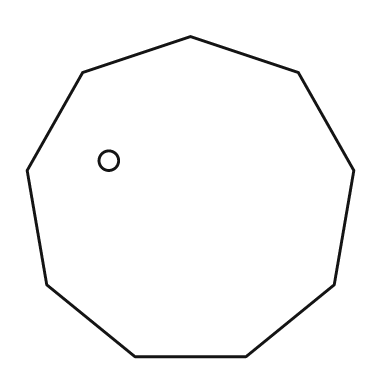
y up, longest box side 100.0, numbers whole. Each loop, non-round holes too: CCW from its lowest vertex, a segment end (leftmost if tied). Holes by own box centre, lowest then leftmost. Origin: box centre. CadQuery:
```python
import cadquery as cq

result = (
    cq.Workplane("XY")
    .moveTo(-17.0, -49.0)
    .lineTo(17.0, -49.0)
    .lineTo(44.0, -27.0)
    .lineTo(50.0, 8.0)
    .lineTo(33.0, 38.0)
    .lineTo(0.0, 49.0)
    .lineTo(-33.0, 38.0)
    .lineTo(-50.0, 8.0)
    .lineTo(-44.0, -27.0)
    .close()
    .moveTo(-25.0, 11.0)
    .circle(3.0)
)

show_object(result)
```